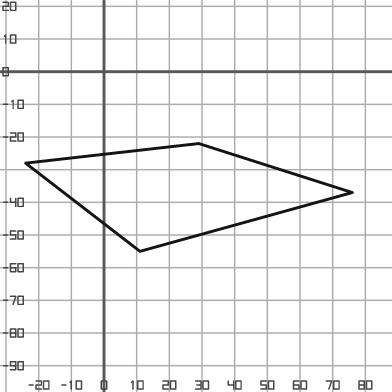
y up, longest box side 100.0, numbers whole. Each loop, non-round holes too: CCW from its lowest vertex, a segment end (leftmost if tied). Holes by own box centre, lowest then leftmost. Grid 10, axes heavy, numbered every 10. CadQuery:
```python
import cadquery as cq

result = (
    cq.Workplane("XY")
    .moveTo(11.0, -55.0)
    .lineTo(76.0, -37.0)
    .lineTo(29.0, -22.0)
    .lineTo(-24.0, -28.0)
    .close()
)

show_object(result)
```